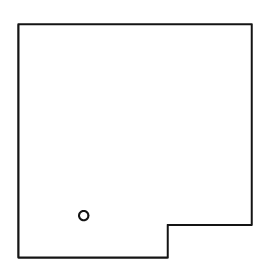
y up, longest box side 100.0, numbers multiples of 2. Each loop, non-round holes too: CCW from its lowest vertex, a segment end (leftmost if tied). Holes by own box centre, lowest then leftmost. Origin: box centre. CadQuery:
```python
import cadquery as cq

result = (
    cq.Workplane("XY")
    .moveTo(-50.0, -50.0)
    .lineTo(14.0, -50.0)
    .lineTo(14.0, -36.0)
    .lineTo(50.0, -36.0)
    .lineTo(50.0, 50.0)
    .lineTo(-50.0, 50.0)
    .close()
    .moveTo(-22.0, -32.0)
    .circle(2.0)
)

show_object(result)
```